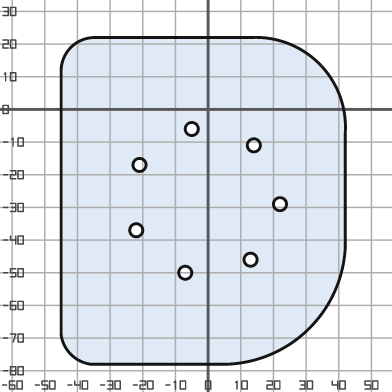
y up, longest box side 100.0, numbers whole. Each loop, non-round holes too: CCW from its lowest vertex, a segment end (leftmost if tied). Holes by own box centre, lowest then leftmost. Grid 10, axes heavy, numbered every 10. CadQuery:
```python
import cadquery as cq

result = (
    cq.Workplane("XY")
    .moveTo(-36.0, -78.0)
    .lineTo(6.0, -78.0)
    .threePointArc((31.0, -67.0), (42.0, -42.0))
    .lineTo(42.0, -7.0)
    .threePointArc((34.0, 14.0), (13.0, 22.0))
    .lineTo(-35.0, 22.0)
    .threePointArc((-42.0, 19.0), (-45.0, 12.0))
    .lineTo(-45.0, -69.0)
    .threePointArc((-42.0, -75.0), (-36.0, -78.0))
    .close()
    .moveTo(-7.0, -50.0)
    .circle(2.0)
    .moveTo(13.0, -46.0)
    .circle(2.0)
    .moveTo(-22.0, -37.0)
    .circle(2.0)
    .moveTo(22.0, -29.0)
    .circle(2.0)
    .moveTo(-21.0, -17.0)
    .circle(2.0)
    .moveTo(14.0, -11.0)
    .circle(2.0)
    .moveTo(-5.0, -6.0)
    .circle(2.0)
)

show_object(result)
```